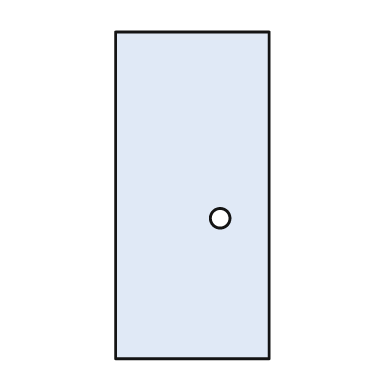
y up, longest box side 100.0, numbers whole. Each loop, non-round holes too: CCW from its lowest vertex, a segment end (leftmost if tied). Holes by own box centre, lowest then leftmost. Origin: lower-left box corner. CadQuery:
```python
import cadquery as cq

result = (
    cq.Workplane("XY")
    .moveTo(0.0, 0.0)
    .lineTo(47.0, 0.0)
    .lineTo(47.0, 100.0)
    .lineTo(0.0, 100.0)
    .close()
    .moveTo(32.0, 43.0)
    .circle(3.0)
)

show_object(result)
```